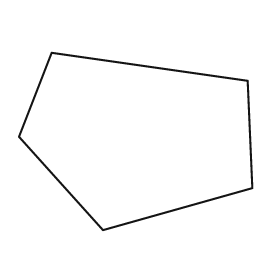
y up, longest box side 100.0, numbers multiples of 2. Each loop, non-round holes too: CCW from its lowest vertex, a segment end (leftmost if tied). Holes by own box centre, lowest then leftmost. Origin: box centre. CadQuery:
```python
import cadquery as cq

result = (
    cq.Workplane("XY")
    .moveTo(-14.0, -38.0)
    .lineTo(50.0, -20.0)
    .lineTo(48.0, 26.0)
    .lineTo(-36.0, 38.0)
    .lineTo(-50.0, 2.0)
    .close()
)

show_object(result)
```